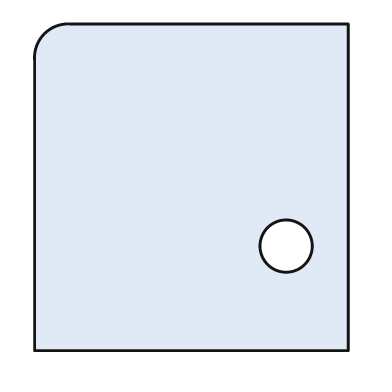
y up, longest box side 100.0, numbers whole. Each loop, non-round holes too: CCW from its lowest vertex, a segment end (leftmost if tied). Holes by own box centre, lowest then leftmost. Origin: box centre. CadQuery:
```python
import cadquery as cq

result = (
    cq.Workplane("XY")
    .moveTo(-48.0, -50.0)
    .lineTo(48.0, -50.0)
    .lineTo(48.0, 50.0)
    .lineTo(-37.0, 50.0)
    .threePointArc((-45.0, 47.0), (-48.0, 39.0))
    .close()
    .moveTo(29.0, -18.0)
    .circle(8.0)
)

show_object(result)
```